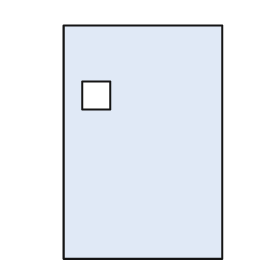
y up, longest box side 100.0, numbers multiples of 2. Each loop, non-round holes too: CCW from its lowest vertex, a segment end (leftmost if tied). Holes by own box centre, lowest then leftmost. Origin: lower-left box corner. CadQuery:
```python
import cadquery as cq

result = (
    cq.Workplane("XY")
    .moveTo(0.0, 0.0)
    .lineTo(68.0, 0.0)
    .lineTo(68.0, 100.0)
    .lineTo(0.0, 100.0)
    .close()
    .moveTo(8.0, 64.0)
    .lineTo(20.0, 64.0)
    .lineTo(20.0, 76.0)
    .lineTo(8.0, 76.0)
    .close()
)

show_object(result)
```